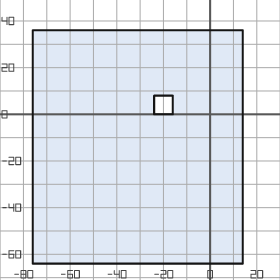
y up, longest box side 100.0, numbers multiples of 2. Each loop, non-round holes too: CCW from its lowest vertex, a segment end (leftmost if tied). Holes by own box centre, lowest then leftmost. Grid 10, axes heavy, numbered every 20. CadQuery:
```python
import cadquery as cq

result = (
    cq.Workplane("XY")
    .moveTo(-76.0, -64.0)
    .lineTo(14.0, -64.0)
    .lineTo(14.0, 36.0)
    .lineTo(-76.0, 36.0)
    .close()
    .moveTo(-24.0, 0.0)
    .lineTo(-16.0, 0.0)
    .lineTo(-16.0, 8.0)
    .lineTo(-24.0, 8.0)
    .close()
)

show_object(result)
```